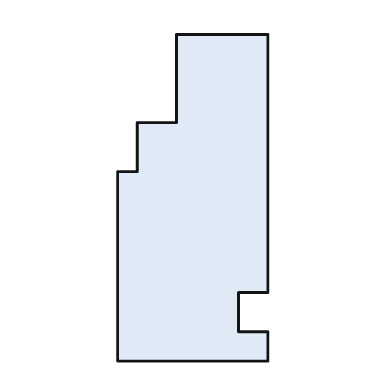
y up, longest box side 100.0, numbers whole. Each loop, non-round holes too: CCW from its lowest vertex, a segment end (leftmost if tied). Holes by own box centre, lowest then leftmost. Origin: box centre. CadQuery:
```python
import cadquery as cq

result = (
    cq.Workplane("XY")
    .moveTo(-23.0, -50.0)
    .lineTo(23.0, -50.0)
    .lineTo(23.0, -41.0)
    .lineTo(14.0, -41.0)
    .lineTo(14.0, -29.0)
    .lineTo(23.0, -29.0)
    .lineTo(23.0, 50.0)
    .lineTo(-5.0, 50.0)
    .lineTo(-5.0, 23.0)
    .lineTo(-17.0, 23.0)
    .lineTo(-17.0, 8.0)
    .lineTo(-23.0, 8.0)
    .close()
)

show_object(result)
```